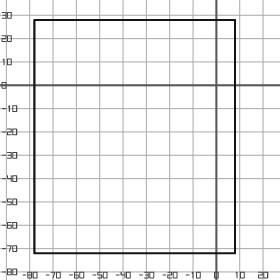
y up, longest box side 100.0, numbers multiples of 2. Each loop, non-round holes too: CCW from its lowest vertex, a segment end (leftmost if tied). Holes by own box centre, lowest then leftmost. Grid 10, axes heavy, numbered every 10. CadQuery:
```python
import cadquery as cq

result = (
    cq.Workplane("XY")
    .moveTo(-78.0, -72.0)
    .lineTo(8.0, -72.0)
    .lineTo(8.0, 28.0)
    .lineTo(-78.0, 28.0)
    .close()
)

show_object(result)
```